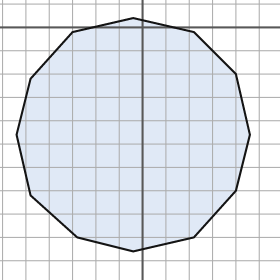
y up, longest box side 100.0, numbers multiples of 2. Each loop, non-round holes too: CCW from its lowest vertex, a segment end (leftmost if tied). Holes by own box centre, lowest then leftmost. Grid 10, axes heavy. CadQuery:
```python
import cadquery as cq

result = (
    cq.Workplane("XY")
    .moveTo(-4.0, -96.0)
    .lineTo(22.0, -90.0)
    .lineTo(40.0, -70.0)
    .lineTo(46.0, -46.0)
    .lineTo(40.0, -20.0)
    .lineTo(22.0, -2.0)
    .lineTo(-4.0, 4.0)
    .lineTo(-30.0, -2.0)
    .lineTo(-48.0, -22.0)
    .lineTo(-54.0, -46.0)
    .lineTo(-48.0, -72.0)
    .lineTo(-28.0, -90.0)
    .close()
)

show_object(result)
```